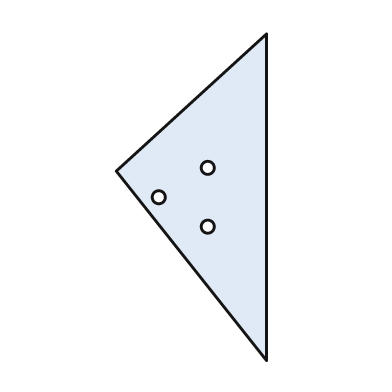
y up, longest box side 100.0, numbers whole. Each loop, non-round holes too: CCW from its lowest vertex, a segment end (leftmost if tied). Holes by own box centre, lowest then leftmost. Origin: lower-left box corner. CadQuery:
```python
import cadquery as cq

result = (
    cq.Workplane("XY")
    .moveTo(46.0, 0.0)
    .lineTo(46.0, 100.0)
    .lineTo(0.0, 58.0)
    .close()
    .moveTo(28.0, 41.0)
    .circle(2.0)
    .moveTo(13.0, 50.0)
    .circle(2.0)
    .moveTo(28.0, 59.0)
    .circle(2.0)
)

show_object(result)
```